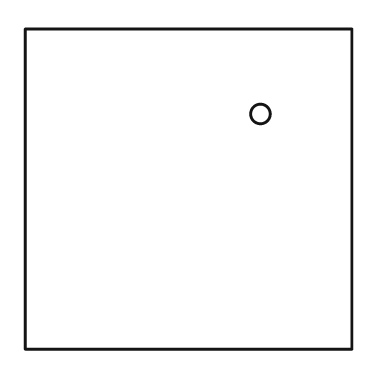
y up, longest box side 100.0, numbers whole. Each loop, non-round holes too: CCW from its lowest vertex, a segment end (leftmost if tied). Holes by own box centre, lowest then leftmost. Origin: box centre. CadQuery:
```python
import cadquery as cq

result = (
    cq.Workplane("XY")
    .moveTo(-50.0, -49.0)
    .lineTo(50.0, -49.0)
    .lineTo(50.0, 49.0)
    .lineTo(-50.0, 49.0)
    .close()
    .moveTo(22.0, 23.0)
    .circle(3.0)
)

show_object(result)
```